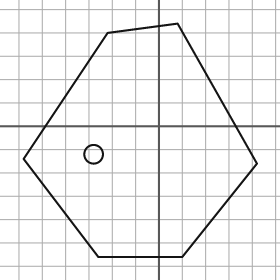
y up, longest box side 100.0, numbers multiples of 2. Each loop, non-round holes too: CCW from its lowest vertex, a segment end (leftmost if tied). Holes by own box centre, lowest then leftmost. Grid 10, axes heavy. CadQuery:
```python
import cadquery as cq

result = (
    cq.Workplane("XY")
    .moveTo(-26.0, -56.0)
    .lineTo(10.0, -56.0)
    .lineTo(42.0, -16.0)
    .lineTo(8.0, 44.0)
    .lineTo(-22.0, 40.0)
    .lineTo(-58.0, -14.0)
    .close()
    .moveTo(-28.0, -12.0)
    .circle(4.0)
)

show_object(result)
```